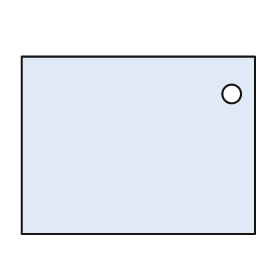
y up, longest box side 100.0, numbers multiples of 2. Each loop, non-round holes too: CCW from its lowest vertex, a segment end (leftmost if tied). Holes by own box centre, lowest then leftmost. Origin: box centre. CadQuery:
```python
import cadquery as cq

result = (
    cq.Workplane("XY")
    .moveTo(-50.0, -38.0)
    .lineTo(50.0, -38.0)
    .lineTo(50.0, 38.0)
    .lineTo(-50.0, 38.0)
    .close()
    .moveTo(40.0, 22.0)
    .circle(4.0)
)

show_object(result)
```